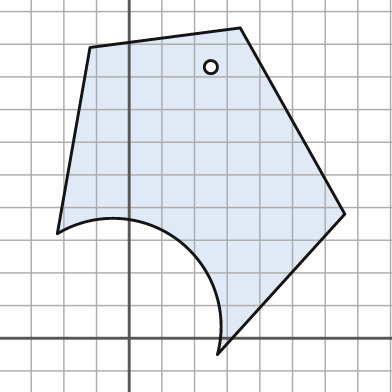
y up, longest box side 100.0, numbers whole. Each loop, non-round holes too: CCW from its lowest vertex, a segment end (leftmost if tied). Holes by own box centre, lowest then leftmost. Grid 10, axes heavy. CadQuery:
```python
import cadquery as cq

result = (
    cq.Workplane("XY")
    .moveTo(27.0, -5.0)
    .lineTo(66.0, 38.0)
    .lineTo(34.0, 95.0)
    .lineTo(-12.0, 89.0)
    .lineTo(-22.0, 32.0)
    .threePointArc((15.0, 30.0), (27.0, -5.0))
    .close()
    .moveTo(25.0, 83.0)
    .circle(2.0)
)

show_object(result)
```